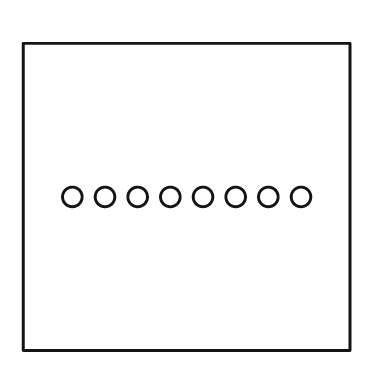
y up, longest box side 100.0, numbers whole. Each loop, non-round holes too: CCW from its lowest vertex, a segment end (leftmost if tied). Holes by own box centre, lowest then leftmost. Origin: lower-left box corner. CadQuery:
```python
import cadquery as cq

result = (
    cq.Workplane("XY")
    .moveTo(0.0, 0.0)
    .lineTo(100.0, 0.0)
    .lineTo(100.0, 94.0)
    .lineTo(0.0, 94.0)
    .close()
    .moveTo(15.0, 47.0)
    .circle(3.0)
    .moveTo(25.0, 47.0)
    .circle(3.0)
    .moveTo(35.0, 47.0)
    .circle(3.0)
    .moveTo(45.0, 47.0)
    .circle(3.0)
    .moveTo(55.0, 47.0)
    .circle(3.0)
    .moveTo(65.0, 47.0)
    .circle(3.0)
    .moveTo(75.0, 47.0)
    .circle(3.0)
    .moveTo(85.0, 47.0)
    .circle(3.0)
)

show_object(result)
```